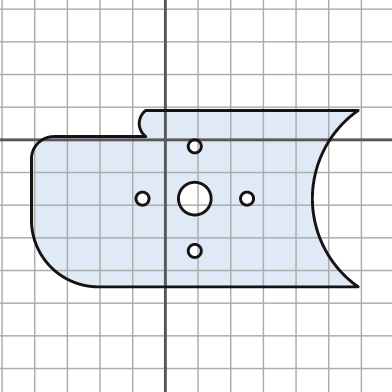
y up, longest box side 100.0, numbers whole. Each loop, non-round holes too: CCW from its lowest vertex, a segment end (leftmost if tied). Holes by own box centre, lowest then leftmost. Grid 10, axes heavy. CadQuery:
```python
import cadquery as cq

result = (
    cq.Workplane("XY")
    .moveTo(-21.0, -45.0)
    .lineTo(59.0, -45.0)
    .threePointArc((45.0, -18.0), (59.0, 9.0))
    .lineTo(-6.0, 9.0)
    .threePointArc((-8.0, 5.0), (-6.0, 1.0))
    .lineTo(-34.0, 1.0)
    .threePointArc((-39.0, -1.0), (-41.0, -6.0))
    .lineTo(-41.0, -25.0)
    .threePointArc((-35.0, -39.0), (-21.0, -45.0))
    .close()
    .moveTo(9.0, -34.0)
    .circle(2.0)
    .moveTo(-7.0, -18.0)
    .circle(2.0)
    .moveTo(9.0, -18.0)
    .circle(5.0)
    .moveTo(25.0, -18.0)
    .circle(2.0)
    .moveTo(9.0, -2.0)
    .circle(2.0)
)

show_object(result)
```